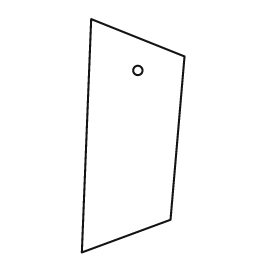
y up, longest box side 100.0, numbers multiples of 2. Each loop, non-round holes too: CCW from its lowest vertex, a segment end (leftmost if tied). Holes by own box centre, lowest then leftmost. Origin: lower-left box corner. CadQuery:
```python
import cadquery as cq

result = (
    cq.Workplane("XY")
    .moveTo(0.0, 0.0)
    .lineTo(38.0, 14.0)
    .lineTo(44.0, 84.0)
    .lineTo(4.0, 100.0)
    .close()
    .moveTo(24.0, 78.0)
    .circle(2.0)
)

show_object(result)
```